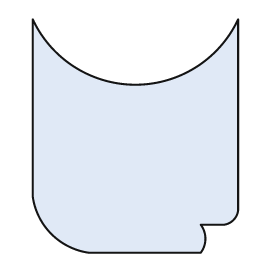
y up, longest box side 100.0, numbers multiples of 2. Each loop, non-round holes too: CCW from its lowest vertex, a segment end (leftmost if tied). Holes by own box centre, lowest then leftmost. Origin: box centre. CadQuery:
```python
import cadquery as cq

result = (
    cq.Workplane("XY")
    .moveTo(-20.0, -50.0)
    .lineTo(28.0, -50.0)
    .threePointArc((30.0, -44.0), (28.0, -38.0))
    .lineTo(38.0, -38.0)
    .threePointArc((42.0, -36.0), (44.0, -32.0))
    .lineTo(44.0, 50.0)
    .threePointArc((0.0, 22.0), (-44.0, 50.0))
    .lineTo(-44.0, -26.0)
    .threePointArc((-36.0, -42.0), (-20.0, -50.0))
    .close()
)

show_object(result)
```